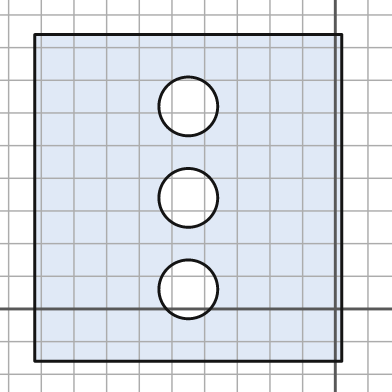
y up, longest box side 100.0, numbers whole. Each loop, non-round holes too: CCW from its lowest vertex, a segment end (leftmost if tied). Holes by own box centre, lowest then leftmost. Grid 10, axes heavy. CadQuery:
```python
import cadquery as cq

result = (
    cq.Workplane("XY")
    .moveTo(-92.0, -16.0)
    .lineTo(2.0, -16.0)
    .lineTo(2.0, 84.0)
    .lineTo(-92.0, 84.0)
    .close()
    .moveTo(-45.0, 6.0)
    .circle(9.0)
    .moveTo(-45.0, 34.0)
    .circle(9.0)
    .moveTo(-45.0, 62.0)
    .circle(9.0)
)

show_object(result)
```